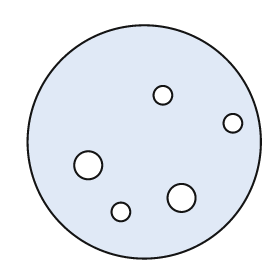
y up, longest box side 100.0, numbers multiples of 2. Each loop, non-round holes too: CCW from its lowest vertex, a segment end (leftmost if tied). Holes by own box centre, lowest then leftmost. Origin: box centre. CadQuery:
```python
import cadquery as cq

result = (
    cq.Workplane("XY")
    .moveTo(0.0, 0.0)
    .circle(50.0)
    .moveTo(-10.0, -30.0)
    .circle(4.0)
    .moveTo(16.0, -24.0)
    .circle(6.0)
    .moveTo(-24.0, -10.0)
    .circle(6.0)
    .moveTo(38.0, 8.0)
    .circle(4.0)
    .moveTo(8.0, 20.0)
    .circle(4.0)
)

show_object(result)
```